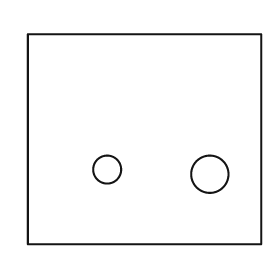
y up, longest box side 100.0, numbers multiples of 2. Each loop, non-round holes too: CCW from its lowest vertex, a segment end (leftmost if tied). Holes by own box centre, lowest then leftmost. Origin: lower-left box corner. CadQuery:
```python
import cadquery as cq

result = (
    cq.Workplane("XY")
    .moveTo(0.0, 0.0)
    .lineTo(100.0, 0.0)
    .lineTo(100.0, 90.0)
    .lineTo(0.0, 90.0)
    .close()
    .moveTo(78.0, 30.0)
    .circle(8.0)
    .moveTo(34.0, 32.0)
    .circle(6.0)
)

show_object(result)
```